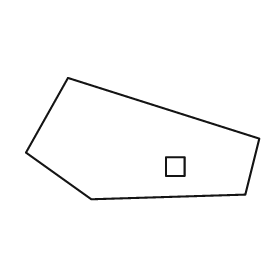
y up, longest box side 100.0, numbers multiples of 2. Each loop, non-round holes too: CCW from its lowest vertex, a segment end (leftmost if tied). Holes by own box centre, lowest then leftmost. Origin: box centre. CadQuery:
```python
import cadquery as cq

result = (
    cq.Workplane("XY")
    .moveTo(-22.0, -26.0)
    .lineTo(44.0, -24.0)
    .lineTo(50.0, 0.0)
    .lineTo(-32.0, 26.0)
    .lineTo(-50.0, -6.0)
    .close()
    .moveTo(10.0, -16.0)
    .lineTo(18.0, -16.0)
    .lineTo(18.0, -8.0)
    .lineTo(10.0, -8.0)
    .close()
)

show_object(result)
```